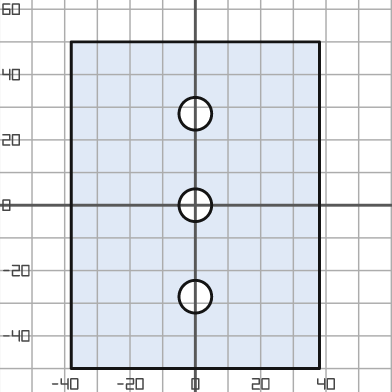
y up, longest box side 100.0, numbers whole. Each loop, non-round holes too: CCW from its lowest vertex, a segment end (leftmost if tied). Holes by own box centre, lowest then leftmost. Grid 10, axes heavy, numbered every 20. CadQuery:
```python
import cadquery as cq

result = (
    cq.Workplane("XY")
    .moveTo(-38.0, -50.0)
    .lineTo(38.0, -50.0)
    .lineTo(38.0, 50.0)
    .lineTo(-38.0, 50.0)
    .close()
    .moveTo(0.0, -28.0)
    .circle(5.0)
    .moveTo(0.0, 0.0)
    .circle(5.0)
    .moveTo(0.0, 28.0)
    .circle(5.0)
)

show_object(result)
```